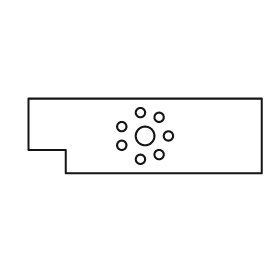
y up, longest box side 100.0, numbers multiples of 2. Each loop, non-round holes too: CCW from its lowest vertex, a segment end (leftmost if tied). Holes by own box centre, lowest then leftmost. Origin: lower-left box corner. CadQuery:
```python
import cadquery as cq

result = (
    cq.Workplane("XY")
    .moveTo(16.0, 0.0)
    .lineTo(100.0, 0.0)
    .lineTo(100.0, 32.0)
    .lineTo(0.0, 32.0)
    .lineTo(0.0, 10.0)
    .lineTo(16.0, 10.0)
    .close()
    .moveTo(48.0, 6.0)
    .circle(2.0)
    .moveTo(56.0, 8.0)
    .circle(2.0)
    .moveTo(40.0, 12.0)
    .circle(2.0)
    .moveTo(50.0, 16.0)
    .circle(4.0)
    .moveTo(60.0, 16.0)
    .circle(2.0)
    .moveTo(40.0, 20.0)
    .circle(2.0)
    .moveTo(56.0, 24.0)
    .circle(2.0)
    .moveTo(48.0, 26.0)
    .circle(2.0)
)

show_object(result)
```